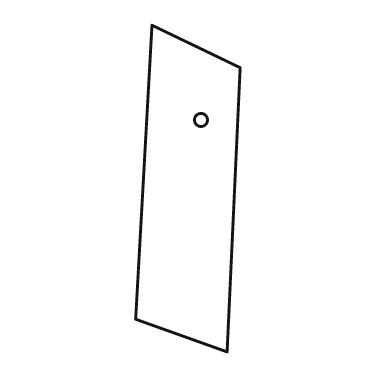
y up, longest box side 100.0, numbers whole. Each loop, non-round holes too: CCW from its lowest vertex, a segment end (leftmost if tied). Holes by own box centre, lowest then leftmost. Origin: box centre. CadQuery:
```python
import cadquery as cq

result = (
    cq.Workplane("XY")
    .moveTo(12.0, -50.0)
    .lineTo(16.0, 37.0)
    .lineTo(-11.0, 50.0)
    .lineTo(-16.0, -40.0)
    .close()
    .moveTo(4.0, 21.0)
    .circle(2.0)
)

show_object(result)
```